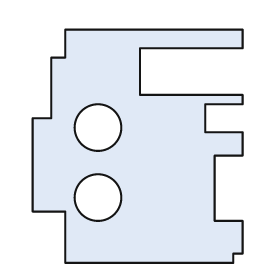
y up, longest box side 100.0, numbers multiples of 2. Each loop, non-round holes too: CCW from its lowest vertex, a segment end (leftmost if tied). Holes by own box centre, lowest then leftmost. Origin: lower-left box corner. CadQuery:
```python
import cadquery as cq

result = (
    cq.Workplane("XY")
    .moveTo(14.0, 0.0)
    .lineTo(86.0, 0.0)
    .lineTo(86.0, 4.0)
    .lineTo(90.0, 4.0)
    .lineTo(90.0, 18.0)
    .lineTo(78.0, 18.0)
    .lineTo(78.0, 46.0)
    .lineTo(90.0, 46.0)
    .lineTo(90.0, 56.0)
    .lineTo(74.0, 56.0)
    .lineTo(74.0, 68.0)
    .lineTo(90.0, 68.0)
    .lineTo(90.0, 72.0)
    .lineTo(46.0, 72.0)
    .lineTo(46.0, 92.0)
    .lineTo(90.0, 92.0)
    .lineTo(90.0, 100.0)
    .lineTo(14.0, 100.0)
    .lineTo(14.0, 88.0)
    .lineTo(8.0, 88.0)
    .lineTo(8.0, 62.0)
    .lineTo(0.0, 62.0)
    .lineTo(0.0, 22.0)
    .lineTo(14.0, 22.0)
    .close()
    .moveTo(28.0, 28.0)
    .circle(10.0)
    .moveTo(28.0, 58.0)
    .circle(10.0)
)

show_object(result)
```